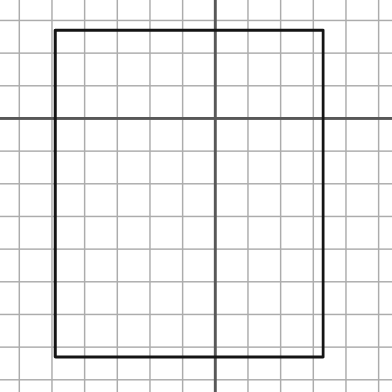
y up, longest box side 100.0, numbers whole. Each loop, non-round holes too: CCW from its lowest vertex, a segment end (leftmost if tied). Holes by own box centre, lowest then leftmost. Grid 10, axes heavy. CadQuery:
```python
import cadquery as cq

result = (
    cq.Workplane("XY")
    .moveTo(-49.0, -73.0)
    .lineTo(33.0, -73.0)
    .lineTo(33.0, 27.0)
    .lineTo(-49.0, 27.0)
    .close()
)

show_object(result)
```